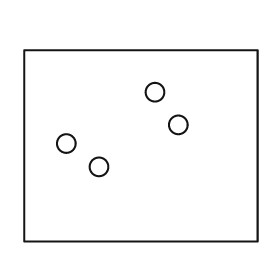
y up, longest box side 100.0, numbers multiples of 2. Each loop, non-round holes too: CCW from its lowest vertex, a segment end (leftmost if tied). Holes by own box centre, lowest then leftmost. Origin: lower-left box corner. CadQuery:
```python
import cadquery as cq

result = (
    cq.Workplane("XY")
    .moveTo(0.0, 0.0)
    .lineTo(100.0, 0.0)
    .lineTo(100.0, 82.0)
    .lineTo(0.0, 82.0)
    .close()
    .moveTo(32.0, 32.0)
    .circle(4.0)
    .moveTo(18.0, 42.0)
    .circle(4.0)
    .moveTo(66.0, 50.0)
    .circle(4.0)
    .moveTo(56.0, 64.0)
    .circle(4.0)
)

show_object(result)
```